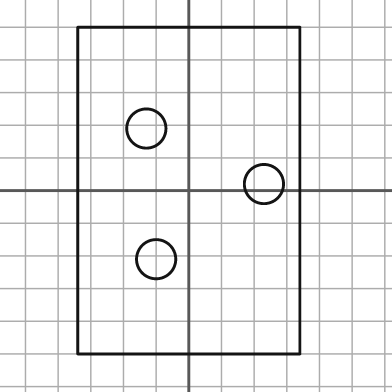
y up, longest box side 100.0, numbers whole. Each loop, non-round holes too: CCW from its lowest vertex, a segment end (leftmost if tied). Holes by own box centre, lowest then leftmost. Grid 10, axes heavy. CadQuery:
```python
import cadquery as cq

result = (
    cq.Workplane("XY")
    .moveTo(-34.0, -50.0)
    .lineTo(34.0, -50.0)
    .lineTo(34.0, 50.0)
    .lineTo(-34.0, 50.0)
    .close()
    .moveTo(-10.0, -21.0)
    .circle(6.0)
    .moveTo(23.0, 2.0)
    .circle(6.0)
    .moveTo(-13.0, 19.0)
    .circle(6.0)
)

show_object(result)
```